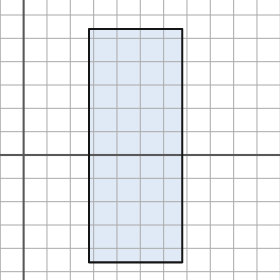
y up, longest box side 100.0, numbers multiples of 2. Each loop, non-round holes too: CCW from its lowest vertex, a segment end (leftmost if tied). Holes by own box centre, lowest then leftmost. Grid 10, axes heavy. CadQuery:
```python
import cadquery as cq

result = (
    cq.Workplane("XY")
    .moveTo(28.0, -46.0)
    .lineTo(68.0, -46.0)
    .lineTo(68.0, 54.0)
    .lineTo(28.0, 54.0)
    .close()
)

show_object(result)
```